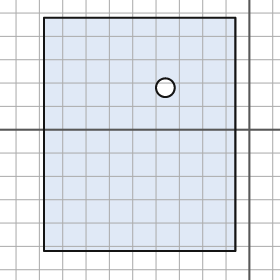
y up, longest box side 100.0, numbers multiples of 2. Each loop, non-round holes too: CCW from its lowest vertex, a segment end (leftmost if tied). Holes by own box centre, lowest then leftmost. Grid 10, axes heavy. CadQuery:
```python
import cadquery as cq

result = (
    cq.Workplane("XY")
    .moveTo(-88.0, -52.0)
    .lineTo(-6.0, -52.0)
    .lineTo(-6.0, 48.0)
    .lineTo(-88.0, 48.0)
    .close()
    .moveTo(-36.0, 18.0)
    .circle(4.0)
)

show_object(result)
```